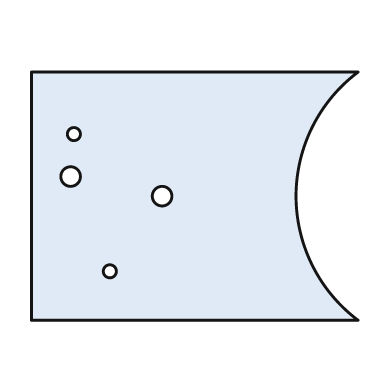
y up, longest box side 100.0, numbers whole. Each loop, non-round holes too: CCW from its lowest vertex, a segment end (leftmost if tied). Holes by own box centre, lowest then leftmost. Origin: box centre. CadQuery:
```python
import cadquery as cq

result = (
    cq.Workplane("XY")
    .moveTo(-50.0, -38.0)
    .lineTo(50.0, -38.0)
    .threePointArc((31.0, 0.0), (50.0, 38.0))
    .lineTo(-50.0, 38.0)
    .close()
    .moveTo(-26.0, -23.0)
    .circle(2.0)
    .moveTo(-10.0, 0.0)
    .circle(3.0)
    .moveTo(-38.0, 6.0)
    .circle(3.0)
    .moveTo(-37.0, 19.0)
    .circle(2.0)
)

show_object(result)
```